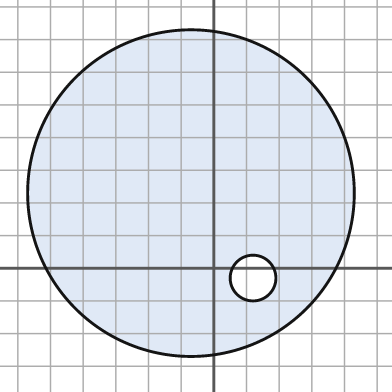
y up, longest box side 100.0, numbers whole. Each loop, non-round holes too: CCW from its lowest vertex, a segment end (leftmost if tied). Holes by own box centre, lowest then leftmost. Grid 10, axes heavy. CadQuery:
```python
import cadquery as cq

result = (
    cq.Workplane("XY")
    .moveTo(-7.0, 23.0)
    .circle(50.0)
    .moveTo(12.0, -3.0)
    .circle(7.0)
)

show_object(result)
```